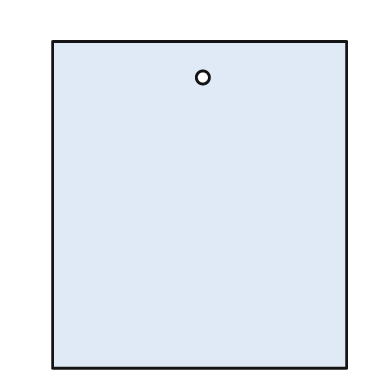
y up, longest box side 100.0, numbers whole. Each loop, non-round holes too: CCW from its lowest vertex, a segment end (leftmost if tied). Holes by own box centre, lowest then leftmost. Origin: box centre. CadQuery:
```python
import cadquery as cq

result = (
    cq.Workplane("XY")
    .moveTo(-45.0, -50.0)
    .lineTo(45.0, -50.0)
    .lineTo(45.0, 50.0)
    .lineTo(-45.0, 50.0)
    .close()
    .moveTo(1.0, 39.0)
    .circle(2.0)
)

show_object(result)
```